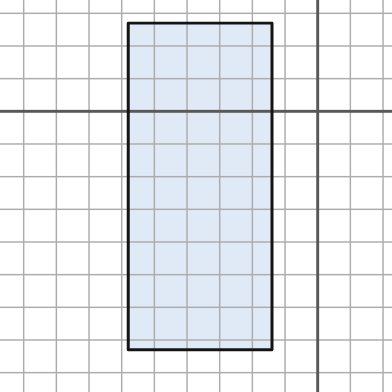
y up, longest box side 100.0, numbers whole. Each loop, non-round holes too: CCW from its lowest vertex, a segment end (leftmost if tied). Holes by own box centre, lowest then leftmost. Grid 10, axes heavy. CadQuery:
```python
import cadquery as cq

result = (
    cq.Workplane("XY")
    .moveTo(-58.0, -73.0)
    .lineTo(-14.0, -73.0)
    .lineTo(-14.0, 27.0)
    .lineTo(-58.0, 27.0)
    .close()
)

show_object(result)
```